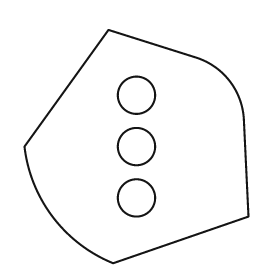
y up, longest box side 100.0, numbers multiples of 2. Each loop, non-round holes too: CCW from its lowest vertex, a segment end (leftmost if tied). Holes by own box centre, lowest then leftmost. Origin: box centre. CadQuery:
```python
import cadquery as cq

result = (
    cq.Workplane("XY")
    .moveTo(-10.0, -50.0)
    .lineTo(48.0, -30.0)
    .lineTo(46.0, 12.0)
    .threePointArc((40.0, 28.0), (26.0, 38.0))
    .lineTo(-12.0, 50.0)
    .lineTo(-48.0, 0.0)
    .threePointArc((-36.0, -30.0), (-10.0, -50.0))
    .close()
    .moveTo(0.0, -22.0)
    .circle(8.0)
    .moveTo(0.0, 0.0)
    .circle(8.0)
    .moveTo(0.0, 22.0)
    .circle(8.0)
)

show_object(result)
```